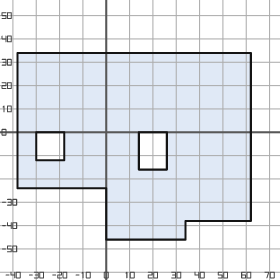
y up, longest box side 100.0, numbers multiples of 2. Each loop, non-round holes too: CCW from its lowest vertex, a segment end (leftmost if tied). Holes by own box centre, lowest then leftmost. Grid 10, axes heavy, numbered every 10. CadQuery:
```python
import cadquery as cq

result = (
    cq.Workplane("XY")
    .moveTo(0.0, -46.0)
    .lineTo(34.0, -46.0)
    .lineTo(34.0, -38.0)
    .lineTo(62.0, -38.0)
    .lineTo(62.0, 34.0)
    .lineTo(-38.0, 34.0)
    .lineTo(-38.0, -24.0)
    .lineTo(0.0, -24.0)
    .close()
    .moveTo(14.0, -16.0)
    .lineTo(26.0, -16.0)
    .lineTo(26.0, 0.0)
    .lineTo(14.0, 0.0)
    .close()
    .moveTo(-30.0, -12.0)
    .lineTo(-18.0, -12.0)
    .lineTo(-18.0, 0.0)
    .lineTo(-30.0, 0.0)
    .close()
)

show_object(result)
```